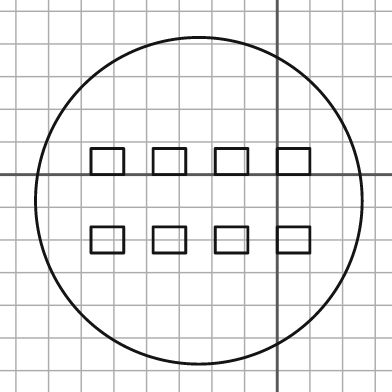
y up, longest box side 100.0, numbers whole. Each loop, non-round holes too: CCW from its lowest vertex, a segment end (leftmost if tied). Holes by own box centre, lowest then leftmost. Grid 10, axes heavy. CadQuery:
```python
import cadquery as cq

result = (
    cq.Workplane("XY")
    .moveTo(-24.0, -8.0)
    .circle(50.0)
    .moveTo(-57.0, -24.0)
    .lineTo(-47.0, -24.0)
    .lineTo(-47.0, -16.0)
    .lineTo(-57.0, -16.0)
    .close()
    .moveTo(-38.0, -24.0)
    .lineTo(-28.0, -24.0)
    .lineTo(-28.0, -16.0)
    .lineTo(-38.0, -16.0)
    .close()
    .moveTo(-19.0, -24.0)
    .lineTo(-9.0, -24.0)
    .lineTo(-9.0, -16.0)
    .lineTo(-19.0, -16.0)
    .close()
    .moveTo(0.0, -24.0)
    .lineTo(10.0, -24.0)
    .lineTo(10.0, -16.0)
    .lineTo(0.0, -16.0)
    .close()
    .moveTo(-57.0, 0.0)
    .lineTo(-47.0, 0.0)
    .lineTo(-47.0, 8.0)
    .lineTo(-57.0, 8.0)
    .close()
    .moveTo(-38.0, 0.0)
    .lineTo(-28.0, 0.0)
    .lineTo(-28.0, 8.0)
    .lineTo(-38.0, 8.0)
    .close()
    .moveTo(-19.0, 0.0)
    .lineTo(-9.0, 0.0)
    .lineTo(-9.0, 8.0)
    .lineTo(-19.0, 8.0)
    .close()
    .moveTo(0.0, 0.0)
    .lineTo(10.0, 0.0)
    .lineTo(10.0, 8.0)
    .lineTo(0.0, 8.0)
    .close()
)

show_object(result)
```